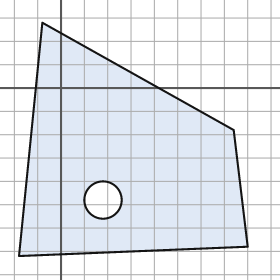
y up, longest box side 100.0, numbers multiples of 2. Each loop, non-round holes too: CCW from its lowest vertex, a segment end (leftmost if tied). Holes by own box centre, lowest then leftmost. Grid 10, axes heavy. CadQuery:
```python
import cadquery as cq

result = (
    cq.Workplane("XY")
    .moveTo(-18.0, -72.0)
    .lineTo(80.0, -68.0)
    .lineTo(74.0, -18.0)
    .lineTo(-8.0, 28.0)
    .close()
    .moveTo(18.0, -48.0)
    .circle(8.0)
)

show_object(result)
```